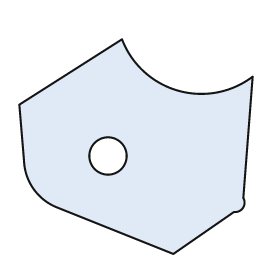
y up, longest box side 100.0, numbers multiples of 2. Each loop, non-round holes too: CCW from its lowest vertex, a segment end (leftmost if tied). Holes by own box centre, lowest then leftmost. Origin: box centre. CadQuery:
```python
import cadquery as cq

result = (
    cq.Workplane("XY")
    .moveTo(16.0, -46.0)
    .lineTo(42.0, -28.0)
    .threePointArc((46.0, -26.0), (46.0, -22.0))
    .lineTo(50.0, 30.0)
    .threePointArc((18.0, 24.0), (-6.0, 46.0))
    .lineTo(-50.0, 18.0)
    .lineTo(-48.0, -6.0)
    .threePointArc((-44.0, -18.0), (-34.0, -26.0))
    .close()
    .moveTo(-12.0, -4.0)
    .circle(8.0)
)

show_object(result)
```